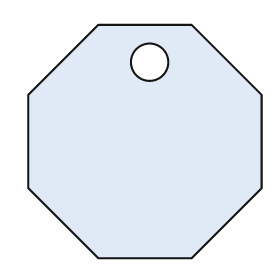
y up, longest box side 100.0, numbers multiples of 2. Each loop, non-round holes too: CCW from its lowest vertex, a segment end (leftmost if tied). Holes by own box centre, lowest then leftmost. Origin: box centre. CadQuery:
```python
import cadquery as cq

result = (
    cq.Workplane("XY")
    .moveTo(-20.0, -50.0)
    .lineTo(20.0, -50.0)
    .lineTo(50.0, -20.0)
    .lineTo(50.0, 20.0)
    .lineTo(20.0, 50.0)
    .lineTo(-20.0, 50.0)
    .lineTo(-50.0, 20.0)
    .lineTo(-50.0, -20.0)
    .close()
    .moveTo(2.0, 34.0)
    .circle(8.0)
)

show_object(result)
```